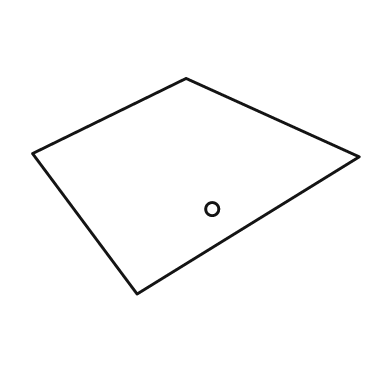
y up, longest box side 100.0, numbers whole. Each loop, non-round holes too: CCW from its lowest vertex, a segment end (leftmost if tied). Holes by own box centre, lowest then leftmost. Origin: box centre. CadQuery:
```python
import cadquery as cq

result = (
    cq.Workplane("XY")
    .moveTo(-18.0, -33.0)
    .lineTo(50.0, 9.0)
    .lineTo(-3.0, 33.0)
    .lineTo(-50.0, 10.0)
    .close()
    .moveTo(5.0, -7.0)
    .circle(2.0)
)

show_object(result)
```